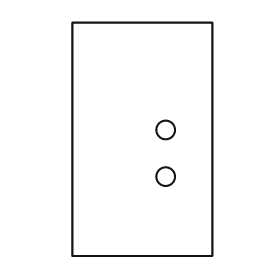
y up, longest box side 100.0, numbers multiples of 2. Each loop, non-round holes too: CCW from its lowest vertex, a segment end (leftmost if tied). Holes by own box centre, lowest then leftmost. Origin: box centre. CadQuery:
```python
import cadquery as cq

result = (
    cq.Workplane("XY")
    .moveTo(-30.0, -50.0)
    .lineTo(30.0, -50.0)
    .lineTo(30.0, 50.0)
    .lineTo(-30.0, 50.0)
    .close()
    .moveTo(10.0, -16.0)
    .circle(4.0)
    .moveTo(10.0, 4.0)
    .circle(4.0)
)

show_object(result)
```